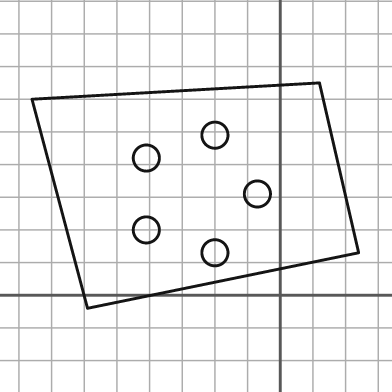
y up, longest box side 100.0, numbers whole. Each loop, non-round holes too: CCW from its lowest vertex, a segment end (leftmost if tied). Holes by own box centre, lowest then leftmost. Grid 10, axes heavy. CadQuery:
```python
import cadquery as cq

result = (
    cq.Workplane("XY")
    .moveTo(-59.0, -4.0)
    .lineTo(24.0, 13.0)
    .lineTo(12.0, 65.0)
    .lineTo(-76.0, 60.0)
    .close()
    .moveTo(-20.0, 13.0)
    .circle(4.0)
    .moveTo(-41.0, 20.0)
    .circle(4.0)
    .moveTo(-7.0, 31.0)
    .circle(4.0)
    .moveTo(-41.0, 42.0)
    .circle(4.0)
    .moveTo(-20.0, 49.0)
    .circle(4.0)
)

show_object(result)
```